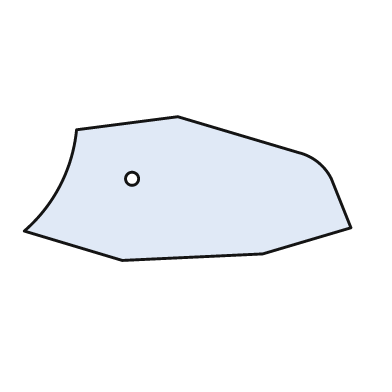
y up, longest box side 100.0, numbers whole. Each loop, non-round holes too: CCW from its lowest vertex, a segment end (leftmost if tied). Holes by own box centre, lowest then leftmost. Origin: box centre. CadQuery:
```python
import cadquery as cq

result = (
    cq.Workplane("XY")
    .moveTo(-20.0, -22.0)
    .lineTo(23.0, -20.0)
    .lineTo(50.0, -12.0)
    .lineTo(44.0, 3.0)
    .threePointArc((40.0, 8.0), (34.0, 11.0))
    .lineTo(-3.0, 22.0)
    .lineTo(-34.0, 18.0)
    .threePointArc((-39.0, 1.0), (-50.0, -13.0))
    .close()
    .moveTo(-17.0, 3.0)
    .circle(2.0)
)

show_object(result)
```